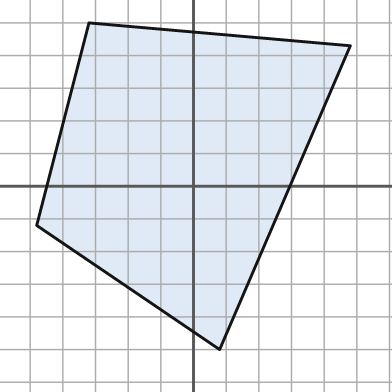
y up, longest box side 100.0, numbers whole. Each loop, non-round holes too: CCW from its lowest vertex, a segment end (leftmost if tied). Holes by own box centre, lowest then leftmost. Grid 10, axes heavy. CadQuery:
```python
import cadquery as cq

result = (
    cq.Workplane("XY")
    .moveTo(8.0, -50.0)
    .lineTo(48.0, 43.0)
    .lineTo(-32.0, 50.0)
    .lineTo(-48.0, -12.0)
    .close()
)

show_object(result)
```